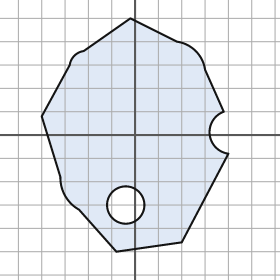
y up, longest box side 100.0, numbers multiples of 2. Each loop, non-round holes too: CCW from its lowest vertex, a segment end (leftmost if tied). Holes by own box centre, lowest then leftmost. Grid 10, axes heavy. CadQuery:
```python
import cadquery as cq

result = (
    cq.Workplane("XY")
    .moveTo(-8.0, -50.0)
    .lineTo(20.0, -46.0)
    .lineTo(40.0, -8.0)
    .threePointArc((32.0, 0.0), (38.0, 10.0))
    .lineTo(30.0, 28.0)
    .threePointArc((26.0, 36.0), (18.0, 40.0))
    .lineTo(-2.0, 50.0)
    .lineTo(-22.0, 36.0)
    .threePointArc((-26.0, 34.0), (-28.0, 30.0))
    .lineTo(-40.0, 8.0)
    .lineTo(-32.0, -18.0)
    .threePointArc((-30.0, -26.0), (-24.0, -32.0))
    .close()
    .moveTo(-4.0, -30.0)
    .circle(8.0)
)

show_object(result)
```